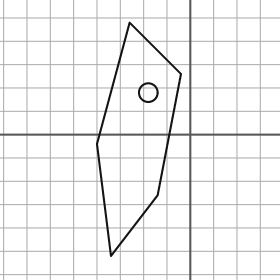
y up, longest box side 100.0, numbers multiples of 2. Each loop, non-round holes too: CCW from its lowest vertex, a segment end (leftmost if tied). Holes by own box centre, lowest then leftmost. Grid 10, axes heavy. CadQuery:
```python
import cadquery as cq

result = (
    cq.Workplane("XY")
    .moveTo(-34.0, -52.0)
    .lineTo(-14.0, -26.0)
    .lineTo(-4.0, 26.0)
    .lineTo(-26.0, 48.0)
    .lineTo(-40.0, -4.0)
    .close()
    .moveTo(-18.0, 18.0)
    .circle(4.0)
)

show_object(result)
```